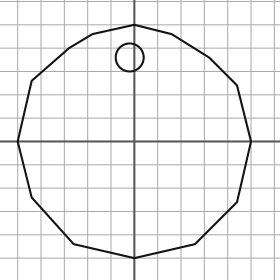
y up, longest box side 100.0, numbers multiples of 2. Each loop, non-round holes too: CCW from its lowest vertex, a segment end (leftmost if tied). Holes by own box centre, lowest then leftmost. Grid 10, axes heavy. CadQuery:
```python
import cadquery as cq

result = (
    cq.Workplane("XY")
    .moveTo(0.0, -50.0)
    .lineTo(26.0, -44.0)
    .lineTo(44.0, -26.0)
    .lineTo(50.0, 0.0)
    .lineTo(44.0, 24.0)
    .lineTo(32.0, 36.0)
    .lineTo(16.0, 46.0)
    .lineTo(0.0, 50.0)
    .lineTo(-18.0, 46.0)
    .lineTo(-28.0, 40.0)
    .lineTo(-44.0, 26.0)
    .lineTo(-50.0, 0.0)
    .lineTo(-44.0, -24.0)
    .lineTo(-26.0, -44.0)
    .close()
    .moveTo(-2.0, 36.0)
    .circle(6.0)
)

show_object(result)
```